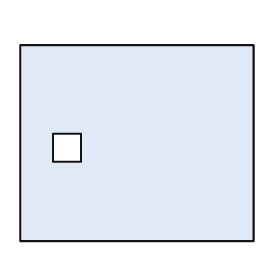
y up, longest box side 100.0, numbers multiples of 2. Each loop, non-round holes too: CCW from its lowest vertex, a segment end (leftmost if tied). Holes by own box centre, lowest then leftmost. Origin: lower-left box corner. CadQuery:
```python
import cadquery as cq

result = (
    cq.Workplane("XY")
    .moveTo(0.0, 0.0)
    .lineTo(100.0, 0.0)
    .lineTo(100.0, 84.0)
    .lineTo(0.0, 84.0)
    .close()
    .moveTo(14.0, 34.0)
    .lineTo(26.0, 34.0)
    .lineTo(26.0, 46.0)
    .lineTo(14.0, 46.0)
    .close()
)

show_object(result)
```